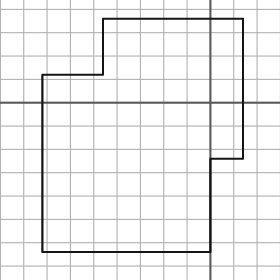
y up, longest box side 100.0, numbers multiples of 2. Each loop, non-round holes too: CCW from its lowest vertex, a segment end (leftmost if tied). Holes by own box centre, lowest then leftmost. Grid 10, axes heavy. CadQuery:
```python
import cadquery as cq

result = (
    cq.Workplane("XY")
    .moveTo(-72.0, -64.0)
    .lineTo(0.0, -64.0)
    .lineTo(0.0, -24.0)
    .lineTo(14.0, -24.0)
    .lineTo(14.0, 36.0)
    .lineTo(-46.0, 36.0)
    .lineTo(-46.0, 12.0)
    .lineTo(-72.0, 12.0)
    .close()
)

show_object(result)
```